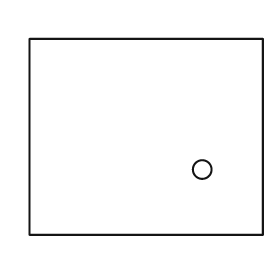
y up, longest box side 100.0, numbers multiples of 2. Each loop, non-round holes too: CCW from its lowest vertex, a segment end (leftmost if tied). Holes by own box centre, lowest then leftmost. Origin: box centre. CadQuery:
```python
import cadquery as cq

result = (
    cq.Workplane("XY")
    .moveTo(-50.0, -42.0)
    .lineTo(50.0, -42.0)
    .lineTo(50.0, 42.0)
    .lineTo(-50.0, 42.0)
    .close()
    .moveTo(24.0, -14.0)
    .circle(4.0)
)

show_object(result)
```